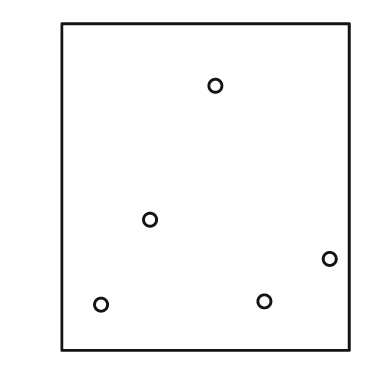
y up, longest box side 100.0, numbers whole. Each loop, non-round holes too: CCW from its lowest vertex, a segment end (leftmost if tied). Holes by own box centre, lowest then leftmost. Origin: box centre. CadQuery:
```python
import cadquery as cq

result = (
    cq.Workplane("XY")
    .moveTo(-44.0, -50.0)
    .lineTo(44.0, -50.0)
    .lineTo(44.0, 50.0)
    .lineTo(-44.0, 50.0)
    .close()
    .moveTo(-32.0, -36.0)
    .circle(2.0)
    .moveTo(18.0, -35.0)
    .circle(2.0)
    .moveTo(38.0, -22.0)
    .circle(2.0)
    .moveTo(-17.0, -10.0)
    .circle(2.0)
    .moveTo(3.0, 31.0)
    .circle(2.0)
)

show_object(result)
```